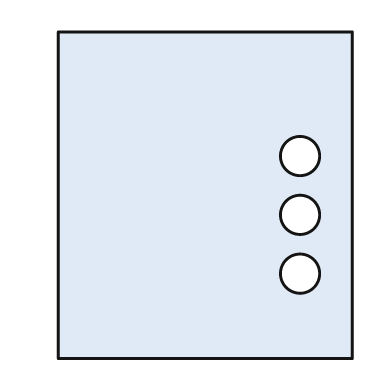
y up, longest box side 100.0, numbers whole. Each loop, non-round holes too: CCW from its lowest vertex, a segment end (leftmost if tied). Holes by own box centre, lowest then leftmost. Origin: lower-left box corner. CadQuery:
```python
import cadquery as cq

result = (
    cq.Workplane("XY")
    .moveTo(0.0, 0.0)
    .lineTo(90.0, 0.0)
    .lineTo(90.0, 100.0)
    .lineTo(0.0, 100.0)
    .close()
    .moveTo(74.0, 26.0)
    .circle(6.0)
    .moveTo(74.0, 44.0)
    .circle(6.0)
    .moveTo(74.0, 62.0)
    .circle(6.0)
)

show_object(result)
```